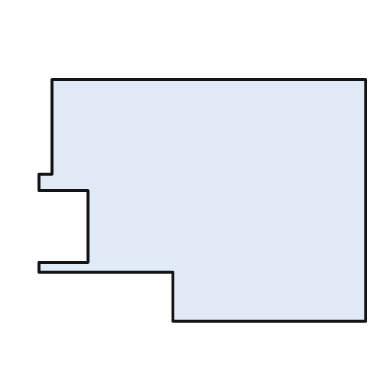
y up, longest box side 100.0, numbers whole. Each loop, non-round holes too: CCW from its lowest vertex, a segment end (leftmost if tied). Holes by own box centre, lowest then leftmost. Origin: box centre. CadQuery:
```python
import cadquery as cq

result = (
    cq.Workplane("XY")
    .moveTo(-9.0, -37.0)
    .lineTo(50.0, -37.0)
    .lineTo(50.0, 37.0)
    .lineTo(-46.0, 37.0)
    .lineTo(-46.0, 8.0)
    .lineTo(-50.0, 8.0)
    .lineTo(-50.0, 3.0)
    .lineTo(-35.0, 3.0)
    .lineTo(-35.0, -19.0)
    .lineTo(-50.0, -19.0)
    .lineTo(-50.0, -22.0)
    .lineTo(-9.0, -22.0)
    .close()
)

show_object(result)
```